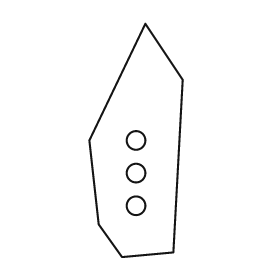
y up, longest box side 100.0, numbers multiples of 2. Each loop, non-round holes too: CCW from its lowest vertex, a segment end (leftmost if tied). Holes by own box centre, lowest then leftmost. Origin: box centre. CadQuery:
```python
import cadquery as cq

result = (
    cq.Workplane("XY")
    .moveTo(-6.0, -50.0)
    .lineTo(16.0, -48.0)
    .lineTo(20.0, 26.0)
    .lineTo(4.0, 50.0)
    .lineTo(-20.0, 0.0)
    .lineTo(-16.0, -36.0)
    .close()
    .moveTo(0.0, -28.0)
    .circle(4.0)
    .moveTo(0.0, -14.0)
    .circle(4.0)
    .moveTo(0.0, 0.0)
    .circle(4.0)
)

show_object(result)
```